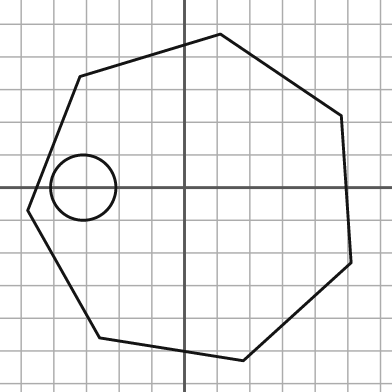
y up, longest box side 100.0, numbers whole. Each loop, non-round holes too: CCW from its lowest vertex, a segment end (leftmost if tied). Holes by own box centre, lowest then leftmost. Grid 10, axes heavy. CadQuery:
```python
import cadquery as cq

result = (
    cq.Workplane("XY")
    .moveTo(18.0, -53.0)
    .lineTo(51.0, -23.0)
    .lineTo(48.0, 22.0)
    .lineTo(11.0, 47.0)
    .lineTo(-32.0, 34.0)
    .lineTo(-48.0, -7.0)
    .lineTo(-26.0, -46.0)
    .close()
    .moveTo(-31.0, 0.0)
    .circle(10.0)
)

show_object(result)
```